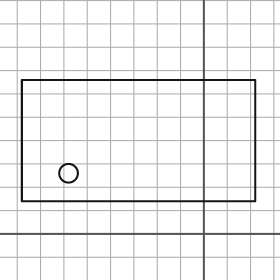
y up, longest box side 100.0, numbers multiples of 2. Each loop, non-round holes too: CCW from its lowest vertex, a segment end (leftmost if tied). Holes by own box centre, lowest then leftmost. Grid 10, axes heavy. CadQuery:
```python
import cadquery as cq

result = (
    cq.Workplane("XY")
    .moveTo(-78.0, 14.0)
    .lineTo(22.0, 14.0)
    .lineTo(22.0, 66.0)
    .lineTo(-78.0, 66.0)
    .close()
    .moveTo(-58.0, 26.0)
    .circle(4.0)
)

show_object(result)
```